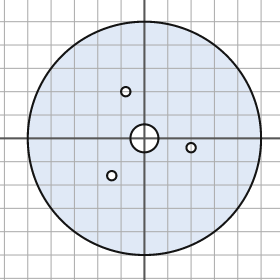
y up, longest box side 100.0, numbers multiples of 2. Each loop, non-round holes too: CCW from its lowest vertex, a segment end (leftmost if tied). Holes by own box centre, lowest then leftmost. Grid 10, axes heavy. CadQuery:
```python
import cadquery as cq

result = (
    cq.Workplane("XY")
    .moveTo(0.0, 0.0)
    .circle(50.0)
    .moveTo(-14.0, -16.0)
    .circle(2.0)
    .moveTo(20.0, -4.0)
    .circle(2.0)
    .moveTo(0.0, 0.0)
    .circle(6.0)
    .moveTo(-8.0, 20.0)
    .circle(2.0)
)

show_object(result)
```